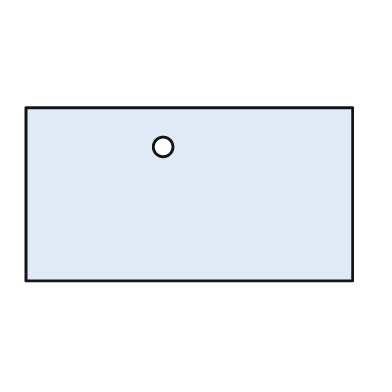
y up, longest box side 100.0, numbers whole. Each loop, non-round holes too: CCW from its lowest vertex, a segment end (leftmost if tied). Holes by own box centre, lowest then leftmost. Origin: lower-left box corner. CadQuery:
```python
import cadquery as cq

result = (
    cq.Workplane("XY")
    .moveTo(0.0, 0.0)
    .lineTo(100.0, 0.0)
    .lineTo(100.0, 53.0)
    .lineTo(0.0, 53.0)
    .close()
    .moveTo(42.0, 41.0)
    .circle(3.0)
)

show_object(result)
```